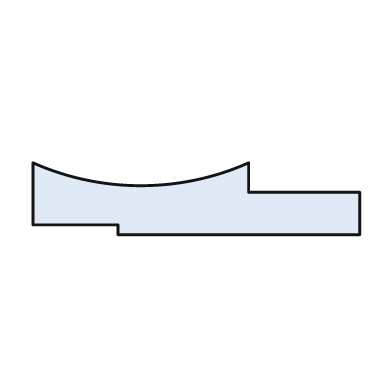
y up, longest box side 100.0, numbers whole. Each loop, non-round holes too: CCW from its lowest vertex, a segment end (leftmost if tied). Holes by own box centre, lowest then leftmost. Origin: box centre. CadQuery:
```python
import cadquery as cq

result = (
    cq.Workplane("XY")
    .moveTo(-24.0, -11.0)
    .lineTo(50.0, -11.0)
    .lineTo(50.0, 2.0)
    .lineTo(16.0, 2.0)
    .lineTo(16.0, 11.0)
    .threePointArc((-17.0, 4.0), (-50.0, 11.0))
    .lineTo(-50.0, -8.0)
    .lineTo(-24.0, -8.0)
    .close()
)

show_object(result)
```